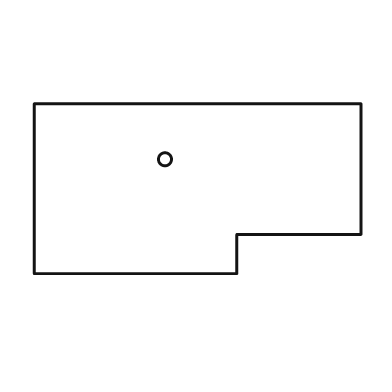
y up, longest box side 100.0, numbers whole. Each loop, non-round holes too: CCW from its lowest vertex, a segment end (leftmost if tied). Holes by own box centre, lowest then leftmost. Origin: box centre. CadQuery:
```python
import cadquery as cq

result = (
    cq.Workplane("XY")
    .moveTo(-50.0, -26.0)
    .lineTo(12.0, -26.0)
    .lineTo(12.0, -14.0)
    .lineTo(50.0, -14.0)
    .lineTo(50.0, 26.0)
    .lineTo(-50.0, 26.0)
    .close()
    .moveTo(-10.0, 9.0)
    .circle(2.0)
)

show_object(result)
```